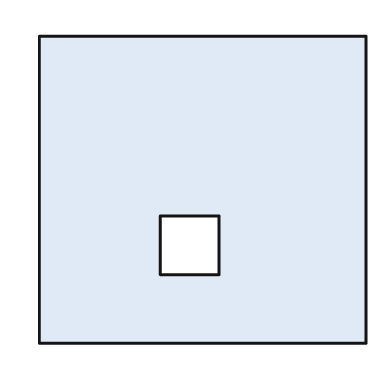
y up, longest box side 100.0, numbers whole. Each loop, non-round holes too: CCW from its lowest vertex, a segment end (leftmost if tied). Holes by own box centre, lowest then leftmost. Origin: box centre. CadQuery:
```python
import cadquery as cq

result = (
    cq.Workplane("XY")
    .moveTo(-50.0, -47.0)
    .lineTo(50.0, -47.0)
    .lineTo(50.0, 47.0)
    .lineTo(-50.0, 47.0)
    .close()
    .moveTo(-13.0, -26.0)
    .lineTo(5.0, -26.0)
    .lineTo(5.0, -8.0)
    .lineTo(-13.0, -8.0)
    .close()
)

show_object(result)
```